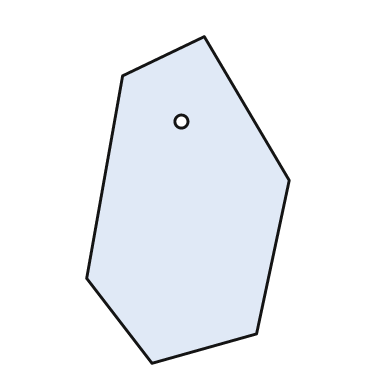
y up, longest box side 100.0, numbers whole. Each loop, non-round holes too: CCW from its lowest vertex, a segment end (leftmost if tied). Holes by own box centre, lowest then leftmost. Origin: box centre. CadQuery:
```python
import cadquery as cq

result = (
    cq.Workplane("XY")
    .moveTo(-11.0, -50.0)
    .lineTo(21.0, -41.0)
    .lineTo(31.0, 6.0)
    .lineTo(5.0, 50.0)
    .lineTo(-20.0, 38.0)
    .lineTo(-31.0, -24.0)
    .close()
    .moveTo(-2.0, 24.0)
    .circle(2.0)
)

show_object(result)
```